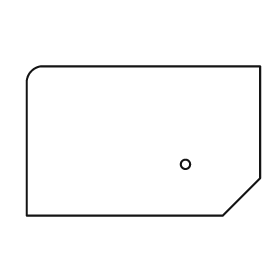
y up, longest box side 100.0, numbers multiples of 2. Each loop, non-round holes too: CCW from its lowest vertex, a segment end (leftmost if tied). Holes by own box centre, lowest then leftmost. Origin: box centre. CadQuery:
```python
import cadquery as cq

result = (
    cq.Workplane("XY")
    .moveTo(-50.0, -32.0)
    .lineTo(34.0, -32.0)
    .lineTo(50.0, -16.0)
    .lineTo(50.0, 32.0)
    .lineTo(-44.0, 32.0)
    .threePointArc((-48.0, 30.0), (-50.0, 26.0))
    .close()
    .moveTo(18.0, -10.0)
    .circle(2.0)
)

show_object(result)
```